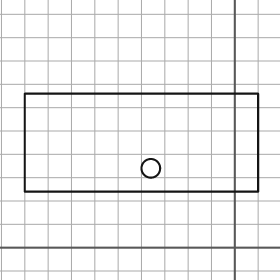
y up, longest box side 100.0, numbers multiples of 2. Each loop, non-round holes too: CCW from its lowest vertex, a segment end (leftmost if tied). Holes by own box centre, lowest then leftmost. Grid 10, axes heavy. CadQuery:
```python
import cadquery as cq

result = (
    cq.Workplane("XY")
    .moveTo(-90.0, 24.0)
    .lineTo(10.0, 24.0)
    .lineTo(10.0, 66.0)
    .lineTo(-90.0, 66.0)
    .close()
    .moveTo(-36.0, 34.0)
    .circle(4.0)
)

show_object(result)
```